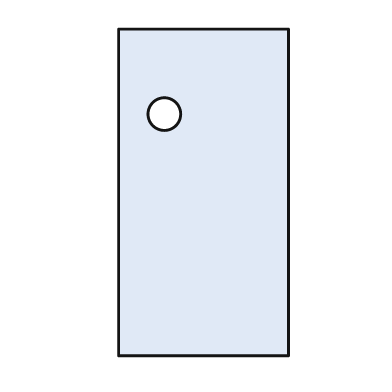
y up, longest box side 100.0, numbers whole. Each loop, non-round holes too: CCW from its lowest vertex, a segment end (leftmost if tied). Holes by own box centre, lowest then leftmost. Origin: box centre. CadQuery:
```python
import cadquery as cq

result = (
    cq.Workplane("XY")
    .moveTo(-26.0, -50.0)
    .lineTo(26.0, -50.0)
    .lineTo(26.0, 50.0)
    .lineTo(-26.0, 50.0)
    .close()
    .moveTo(-12.0, 24.0)
    .circle(5.0)
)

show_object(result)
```